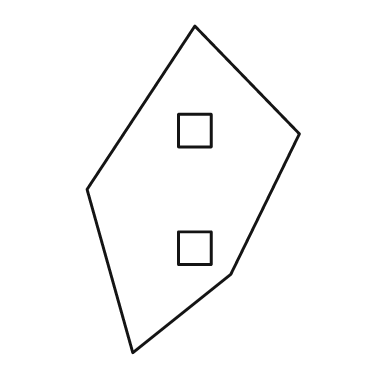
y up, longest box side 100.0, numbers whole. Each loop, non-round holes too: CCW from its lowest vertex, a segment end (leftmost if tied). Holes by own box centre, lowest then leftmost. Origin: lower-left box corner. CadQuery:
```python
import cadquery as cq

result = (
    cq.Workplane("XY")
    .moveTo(14.0, 0.0)
    .lineTo(44.0, 24.0)
    .lineTo(65.0, 67.0)
    .lineTo(33.0, 100.0)
    .lineTo(0.0, 50.0)
    .close()
    .moveTo(28.0, 27.0)
    .lineTo(38.0, 27.0)
    .lineTo(38.0, 37.0)
    .lineTo(28.0, 37.0)
    .close()
    .moveTo(28.0, 63.0)
    .lineTo(38.0, 63.0)
    .lineTo(38.0, 73.0)
    .lineTo(28.0, 73.0)
    .close()
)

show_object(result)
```